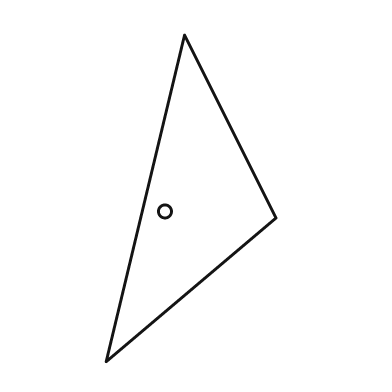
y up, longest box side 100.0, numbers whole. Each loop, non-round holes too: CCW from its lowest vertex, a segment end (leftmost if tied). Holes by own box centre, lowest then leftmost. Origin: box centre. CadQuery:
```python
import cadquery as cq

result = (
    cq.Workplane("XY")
    .moveTo(-26.0, -50.0)
    .lineTo(26.0, -6.0)
    .lineTo(-2.0, 50.0)
    .close()
    .moveTo(-8.0, -4.0)
    .circle(2.0)
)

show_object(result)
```